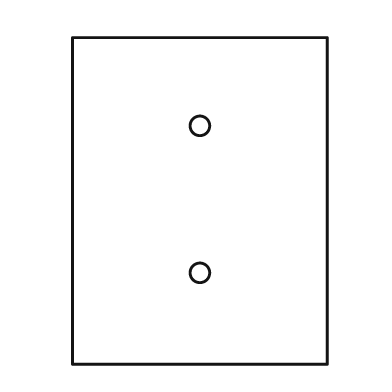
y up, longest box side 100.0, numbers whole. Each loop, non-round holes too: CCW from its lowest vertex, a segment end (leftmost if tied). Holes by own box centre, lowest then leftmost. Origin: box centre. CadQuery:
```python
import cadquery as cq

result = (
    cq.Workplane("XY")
    .moveTo(-39.0, -50.0)
    .lineTo(39.0, -50.0)
    .lineTo(39.0, 50.0)
    .lineTo(-39.0, 50.0)
    .close()
    .moveTo(0.0, -22.0)
    .circle(3.0)
    .moveTo(0.0, 23.0)
    .circle(3.0)
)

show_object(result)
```